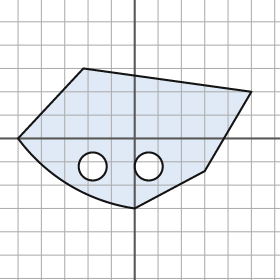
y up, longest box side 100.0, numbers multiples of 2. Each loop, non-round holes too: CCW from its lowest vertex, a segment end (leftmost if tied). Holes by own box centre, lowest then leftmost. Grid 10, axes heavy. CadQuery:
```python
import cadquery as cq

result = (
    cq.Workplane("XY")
    .moveTo(0.0, -30.0)
    .lineTo(30.0, -14.0)
    .lineTo(50.0, 20.0)
    .lineTo(-22.0, 30.0)
    .lineTo(-50.0, 0.0)
    .threePointArc((-28.0, -20.0), (0.0, -30.0))
    .close()
    .moveTo(-18.0, -12.0)
    .circle(6.0)
    .moveTo(6.0, -12.0)
    .circle(6.0)
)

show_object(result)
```